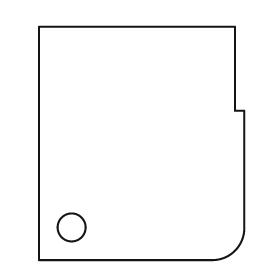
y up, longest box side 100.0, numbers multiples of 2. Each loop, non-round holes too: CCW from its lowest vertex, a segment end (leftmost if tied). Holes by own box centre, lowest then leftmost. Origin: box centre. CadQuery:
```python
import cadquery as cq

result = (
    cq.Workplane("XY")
    .moveTo(-44.0, -50.0)
    .lineTo(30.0, -50.0)
    .threePointArc((40.0, -46.0), (44.0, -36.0))
    .lineTo(44.0, 14.0)
    .lineTo(40.0, 14.0)
    .lineTo(40.0, 50.0)
    .lineTo(-44.0, 50.0)
    .close()
    .moveTo(-30.0, -36.0)
    .circle(6.0)
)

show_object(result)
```